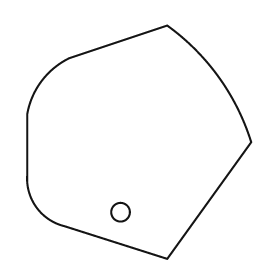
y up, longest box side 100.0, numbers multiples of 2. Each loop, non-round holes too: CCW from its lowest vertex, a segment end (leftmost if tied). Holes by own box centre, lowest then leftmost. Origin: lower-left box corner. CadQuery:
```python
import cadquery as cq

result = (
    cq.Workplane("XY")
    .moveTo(60.0, 0.0)
    .lineTo(96.0, 50.0)
    .threePointArc((82.0, 78.0), (60.0, 100.0))
    .lineTo(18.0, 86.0)
    .threePointArc((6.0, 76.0), (0.0, 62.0))
    .lineTo(0.0, 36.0)
    .threePointArc((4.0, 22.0), (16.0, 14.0))
    .close()
    .moveTo(40.0, 20.0)
    .circle(4.0)
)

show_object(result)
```